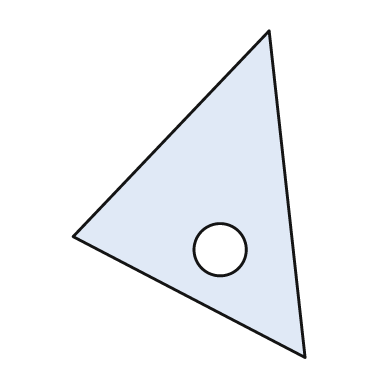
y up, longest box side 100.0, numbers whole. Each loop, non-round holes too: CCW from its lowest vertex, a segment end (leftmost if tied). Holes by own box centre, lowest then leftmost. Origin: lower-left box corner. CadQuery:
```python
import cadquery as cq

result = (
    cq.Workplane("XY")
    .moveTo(71.0, 0.0)
    .lineTo(60.0, 100.0)
    .lineTo(0.0, 37.0)
    .close()
    .moveTo(45.0, 33.0)
    .circle(8.0)
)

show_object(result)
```